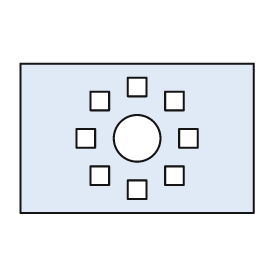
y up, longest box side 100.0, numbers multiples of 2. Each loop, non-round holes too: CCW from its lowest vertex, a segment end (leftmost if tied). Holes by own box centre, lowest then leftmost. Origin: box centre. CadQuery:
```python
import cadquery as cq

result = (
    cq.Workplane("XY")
    .moveTo(-50.0, -32.0)
    .lineTo(50.0, -32.0)
    .lineTo(50.0, 32.0)
    .lineTo(-50.0, 32.0)
    .close()
    .moveTo(-4.0, -26.0)
    .lineTo(4.0, -26.0)
    .lineTo(4.0, -18.0)
    .lineTo(-4.0, -18.0)
    .close()
    .moveTo(-20.0, -20.0)
    .lineTo(-12.0, -20.0)
    .lineTo(-12.0, -12.0)
    .lineTo(-20.0, -12.0)
    .close()
    .moveTo(12.0, -20.0)
    .lineTo(20.0, -20.0)
    .lineTo(20.0, -12.0)
    .lineTo(12.0, -12.0)
    .close()
    .moveTo(-26.0, -4.0)
    .lineTo(-18.0, -4.0)
    .lineTo(-18.0, 4.0)
    .lineTo(-26.0, 4.0)
    .close()
    .moveTo(0.0, 0.0)
    .circle(10.0)
    .moveTo(18.0, -4.0)
    .lineTo(26.0, -4.0)
    .lineTo(26.0, 4.0)
    .lineTo(18.0, 4.0)
    .close()
    .moveTo(-20.0, 12.0)
    .lineTo(-12.0, 12.0)
    .lineTo(-12.0, 20.0)
    .lineTo(-20.0, 20.0)
    .close()
    .moveTo(12.0, 12.0)
    .lineTo(20.0, 12.0)
    .lineTo(20.0, 20.0)
    .lineTo(12.0, 20.0)
    .close()
    .moveTo(-4.0, 18.0)
    .lineTo(4.0, 18.0)
    .lineTo(4.0, 26.0)
    .lineTo(-4.0, 26.0)
    .close()
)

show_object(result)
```